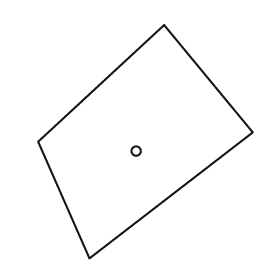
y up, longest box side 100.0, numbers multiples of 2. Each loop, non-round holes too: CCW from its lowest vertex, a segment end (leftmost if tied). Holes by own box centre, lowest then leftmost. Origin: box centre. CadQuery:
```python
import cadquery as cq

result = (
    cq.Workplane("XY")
    .moveTo(-24.0, -50.0)
    .lineTo(46.0, 4.0)
    .lineTo(8.0, 50.0)
    .lineTo(-46.0, 0.0)
    .close()
    .moveTo(-4.0, -4.0)
    .circle(2.0)
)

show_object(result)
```